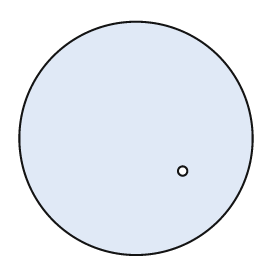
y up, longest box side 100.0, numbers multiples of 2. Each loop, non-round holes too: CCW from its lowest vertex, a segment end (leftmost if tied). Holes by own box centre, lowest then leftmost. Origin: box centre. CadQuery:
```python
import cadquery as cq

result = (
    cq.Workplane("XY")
    .moveTo(0.0, 0.0)
    .circle(50.0)
    .moveTo(20.0, -14.0)
    .circle(2.0)
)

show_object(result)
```